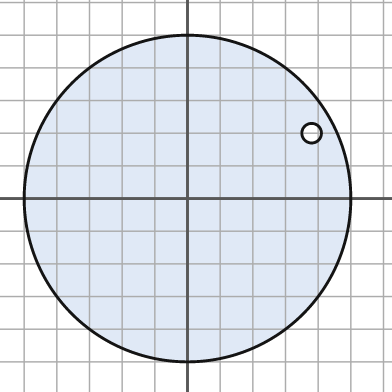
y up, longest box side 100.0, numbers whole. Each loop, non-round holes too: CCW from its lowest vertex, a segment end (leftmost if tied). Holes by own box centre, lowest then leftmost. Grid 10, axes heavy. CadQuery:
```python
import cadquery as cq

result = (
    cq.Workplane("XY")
    .moveTo(0.0, 0.0)
    .circle(50.0)
    .moveTo(38.0, 20.0)
    .circle(3.0)
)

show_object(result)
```